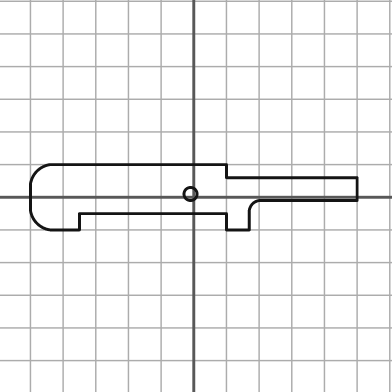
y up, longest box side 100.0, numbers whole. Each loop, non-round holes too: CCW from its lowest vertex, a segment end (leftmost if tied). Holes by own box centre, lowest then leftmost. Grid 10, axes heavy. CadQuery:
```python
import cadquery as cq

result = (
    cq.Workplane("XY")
    .moveTo(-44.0, -10.0)
    .lineTo(-35.0, -10.0)
    .lineTo(-35.0, -5.0)
    .lineTo(10.0, -5.0)
    .lineTo(10.0, -10.0)
    .lineTo(17.0, -10.0)
    .lineTo(17.0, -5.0)
    .threePointArc((18.0, -2.0), (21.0, -1.0))
    .lineTo(50.0, -1.0)
    .lineTo(50.0, 6.0)
    .lineTo(10.0, 6.0)
    .lineTo(10.0, 10.0)
    .lineTo(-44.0, 10.0)
    .threePointArc((-48.0, 8.0), (-50.0, 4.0))
    .lineTo(-50.0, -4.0)
    .threePointArc((-48.0, -8.0), (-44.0, -10.0))
    .close()
    .moveTo(-1.0, 1.0)
    .circle(2.0)
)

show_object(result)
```